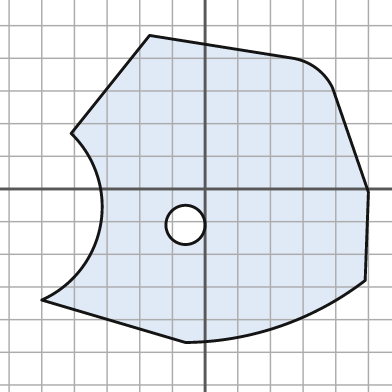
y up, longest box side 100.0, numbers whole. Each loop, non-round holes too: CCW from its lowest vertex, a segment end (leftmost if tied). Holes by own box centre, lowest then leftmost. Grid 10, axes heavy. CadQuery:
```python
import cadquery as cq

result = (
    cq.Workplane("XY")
    .moveTo(-6.0, -47.0)
    .threePointArc((23.0, -42.0), (49.0, -28.0))
    .lineTo(50.0, -1.0)
    .lineTo(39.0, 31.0)
    .threePointArc((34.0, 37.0), (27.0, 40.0))
    .lineTo(-17.0, 47.0)
    .lineTo(-41.0, 17.0)
    .threePointArc((-32.0, -11.0), (-50.0, -34.0))
    .close()
    .moveTo(-6.0, -11.0)
    .circle(6.0)
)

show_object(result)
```